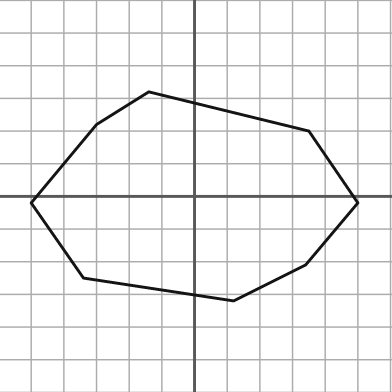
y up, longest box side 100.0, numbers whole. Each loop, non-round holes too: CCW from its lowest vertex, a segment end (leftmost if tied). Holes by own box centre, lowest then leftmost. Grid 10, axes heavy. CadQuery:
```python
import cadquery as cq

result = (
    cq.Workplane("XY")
    .moveTo(12.0, -32.0)
    .lineTo(34.0, -21.0)
    .lineTo(50.0, -2.0)
    .lineTo(35.0, 20.0)
    .lineTo(-14.0, 32.0)
    .lineTo(-30.0, 22.0)
    .lineTo(-50.0, -2.0)
    .lineTo(-34.0, -25.0)
    .close()
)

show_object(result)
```